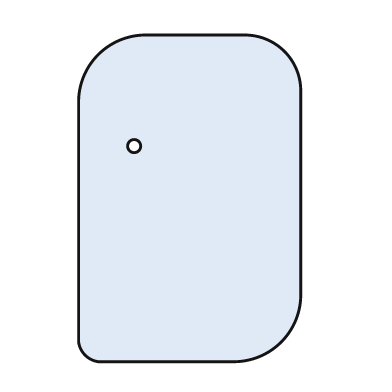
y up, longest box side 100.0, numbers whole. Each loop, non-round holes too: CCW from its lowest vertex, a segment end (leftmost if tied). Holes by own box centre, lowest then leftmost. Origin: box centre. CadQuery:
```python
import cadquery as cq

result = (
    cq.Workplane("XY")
    .moveTo(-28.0, -50.0)
    .lineTo(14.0, -50.0)
    .threePointArc((28.0, -44.0), (34.0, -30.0))
    .lineTo(34.0, 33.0)
    .threePointArc((29.0, 45.0), (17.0, 50.0))
    .lineTo(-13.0, 50.0)
    .threePointArc((-28.0, 44.0), (-34.0, 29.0))
    .lineTo(-34.0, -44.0)
    .threePointArc((-32.0, -48.0), (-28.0, -50.0))
    .close()
    .moveTo(-17.0, 16.0)
    .circle(2.0)
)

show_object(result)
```